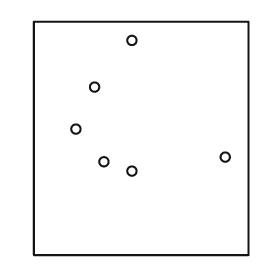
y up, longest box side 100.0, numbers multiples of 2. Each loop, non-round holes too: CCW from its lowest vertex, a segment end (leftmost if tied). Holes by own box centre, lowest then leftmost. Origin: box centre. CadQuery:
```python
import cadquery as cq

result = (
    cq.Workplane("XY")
    .moveTo(-46.0, -50.0)
    .lineTo(46.0, -50.0)
    .lineTo(46.0, 50.0)
    .lineTo(-46.0, 50.0)
    .close()
    .moveTo(-4.0, -14.0)
    .circle(2.0)
    .moveTo(-16.0, -10.0)
    .circle(2.0)
    .moveTo(36.0, -8.0)
    .circle(2.0)
    .moveTo(-28.0, 4.0)
    .circle(2.0)
    .moveTo(-20.0, 22.0)
    .circle(2.0)
    .moveTo(-4.0, 42.0)
    .circle(2.0)
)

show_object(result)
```